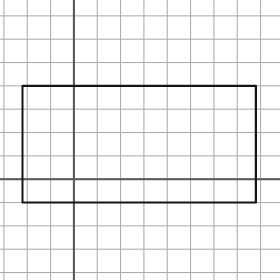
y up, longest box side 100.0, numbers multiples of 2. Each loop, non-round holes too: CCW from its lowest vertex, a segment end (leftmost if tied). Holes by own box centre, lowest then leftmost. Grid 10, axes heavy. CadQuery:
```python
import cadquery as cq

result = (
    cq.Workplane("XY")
    .moveTo(-22.0, -10.0)
    .lineTo(78.0, -10.0)
    .lineTo(78.0, 40.0)
    .lineTo(-22.0, 40.0)
    .close()
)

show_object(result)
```